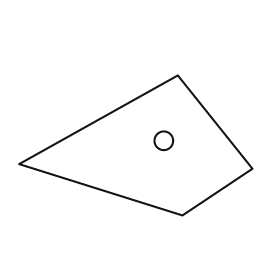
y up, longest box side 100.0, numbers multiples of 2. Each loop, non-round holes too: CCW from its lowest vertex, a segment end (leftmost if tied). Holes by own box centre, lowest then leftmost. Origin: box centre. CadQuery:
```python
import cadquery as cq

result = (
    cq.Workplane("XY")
    .moveTo(20.0, -30.0)
    .lineTo(50.0, -10.0)
    .lineTo(18.0, 30.0)
    .lineTo(-50.0, -8.0)
    .close()
    .moveTo(12.0, 2.0)
    .circle(4.0)
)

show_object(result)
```